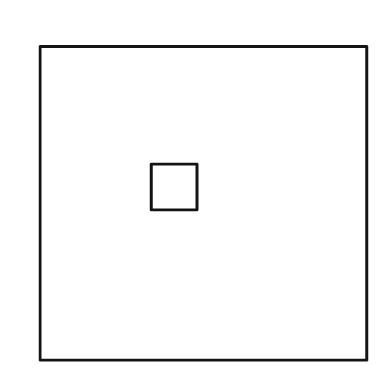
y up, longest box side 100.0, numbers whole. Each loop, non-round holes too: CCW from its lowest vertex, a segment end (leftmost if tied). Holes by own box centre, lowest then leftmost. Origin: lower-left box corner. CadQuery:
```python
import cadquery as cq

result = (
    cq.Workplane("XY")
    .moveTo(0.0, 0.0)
    .lineTo(100.0, 0.0)
    .lineTo(100.0, 96.0)
    .lineTo(0.0, 96.0)
    .close()
    .moveTo(34.0, 46.0)
    .lineTo(48.0, 46.0)
    .lineTo(48.0, 60.0)
    .lineTo(34.0, 60.0)
    .close()
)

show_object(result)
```